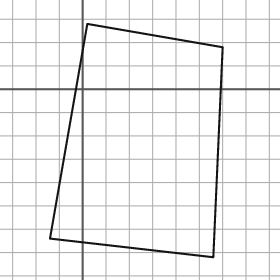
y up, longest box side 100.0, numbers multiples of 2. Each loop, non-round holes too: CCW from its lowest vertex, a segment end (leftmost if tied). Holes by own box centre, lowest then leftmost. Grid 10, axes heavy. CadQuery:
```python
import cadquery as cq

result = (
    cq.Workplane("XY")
    .moveTo(56.0, -72.0)
    .lineTo(60.0, 18.0)
    .lineTo(2.0, 28.0)
    .lineTo(-14.0, -64.0)
    .close()
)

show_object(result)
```